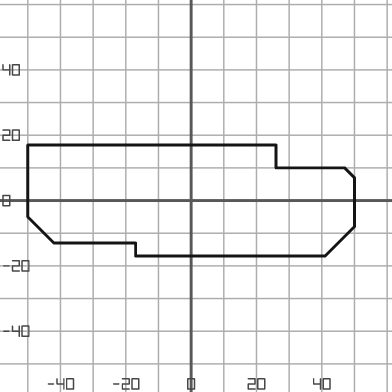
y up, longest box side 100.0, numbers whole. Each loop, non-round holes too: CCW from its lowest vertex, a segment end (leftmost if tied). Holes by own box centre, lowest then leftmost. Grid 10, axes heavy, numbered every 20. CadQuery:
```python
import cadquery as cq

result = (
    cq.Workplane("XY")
    .moveTo(-17.0, -17.0)
    .lineTo(41.0, -17.0)
    .lineTo(50.0, -8.0)
    .lineTo(50.0, 7.0)
    .lineTo(47.0, 10.0)
    .lineTo(26.0, 10.0)
    .lineTo(26.0, 17.0)
    .lineTo(-50.0, 17.0)
    .lineTo(-50.0, -5.0)
    .lineTo(-42.0, -13.0)
    .lineTo(-17.0, -13.0)
    .close()
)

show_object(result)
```